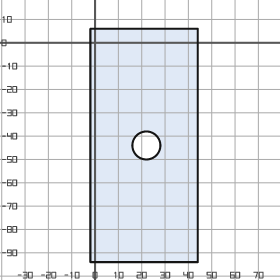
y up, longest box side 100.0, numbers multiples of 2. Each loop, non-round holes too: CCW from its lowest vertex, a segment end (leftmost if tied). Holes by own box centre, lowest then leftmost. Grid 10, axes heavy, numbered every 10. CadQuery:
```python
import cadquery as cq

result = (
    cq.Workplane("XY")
    .moveTo(-2.0, -94.0)
    .lineTo(44.0, -94.0)
    .lineTo(44.0, 6.0)
    .lineTo(-2.0, 6.0)
    .close()
    .moveTo(22.0, -44.0)
    .circle(6.0)
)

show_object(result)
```